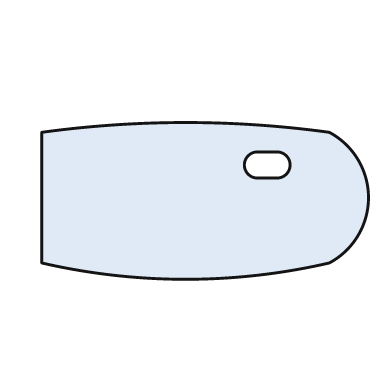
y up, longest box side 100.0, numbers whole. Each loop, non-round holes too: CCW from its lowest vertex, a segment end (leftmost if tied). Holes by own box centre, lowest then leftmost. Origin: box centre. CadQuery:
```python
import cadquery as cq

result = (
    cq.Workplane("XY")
    .moveTo(-50.0, -19.0)
    .threePointArc((-6.0, -24.0), (38.0, -19.0))
    .threePointArc((50.0, 1.0), (38.0, 21.0))
    .threePointArc((-6.0, 24.0), (-50.0, 21.0))
    .close()
    .moveTo(16.0, 7.0)
    .lineTo(22.0, 7.0)
    .threePointArc((26.0, 11.0), (22.0, 15.0))
    .lineTo(16.0, 15.0)
    .threePointArc((12.0, 11.0), (16.0, 7.0))
    .close()
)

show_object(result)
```